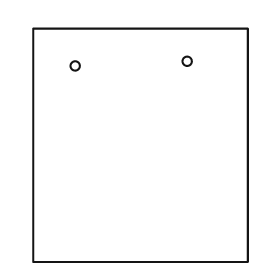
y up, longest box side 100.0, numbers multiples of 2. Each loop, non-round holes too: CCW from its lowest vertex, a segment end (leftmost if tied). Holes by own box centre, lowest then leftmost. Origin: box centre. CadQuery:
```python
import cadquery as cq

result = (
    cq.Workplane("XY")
    .moveTo(-46.0, -50.0)
    .lineTo(46.0, -50.0)
    .lineTo(46.0, 50.0)
    .lineTo(-46.0, 50.0)
    .close()
    .moveTo(-28.0, 34.0)
    .circle(2.0)
    .moveTo(20.0, 36.0)
    .circle(2.0)
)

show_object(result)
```